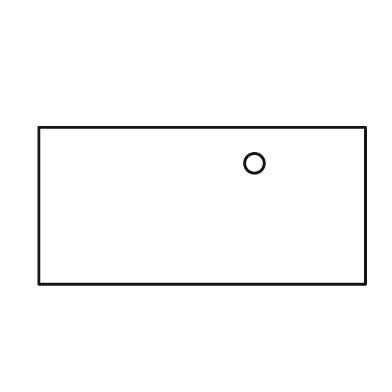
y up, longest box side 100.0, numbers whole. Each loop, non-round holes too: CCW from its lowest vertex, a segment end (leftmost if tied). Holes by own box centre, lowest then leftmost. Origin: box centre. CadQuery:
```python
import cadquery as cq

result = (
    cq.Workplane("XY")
    .moveTo(-50.0, -24.0)
    .lineTo(50.0, -24.0)
    .lineTo(50.0, 24.0)
    .lineTo(-50.0, 24.0)
    .close()
    .moveTo(16.0, 13.0)
    .circle(3.0)
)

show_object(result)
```